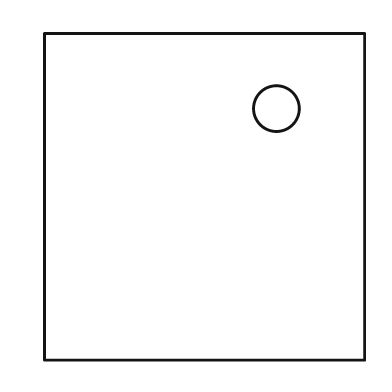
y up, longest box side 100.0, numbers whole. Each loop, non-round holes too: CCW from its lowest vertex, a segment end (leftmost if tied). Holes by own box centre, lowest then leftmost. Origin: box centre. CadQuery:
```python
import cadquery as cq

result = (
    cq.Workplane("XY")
    .moveTo(-49.0, -50.0)
    .lineTo(49.0, -50.0)
    .lineTo(49.0, 50.0)
    .lineTo(-49.0, 50.0)
    .close()
    .moveTo(22.0, 27.0)
    .circle(7.0)
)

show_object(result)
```